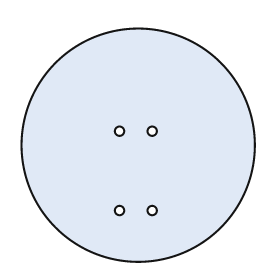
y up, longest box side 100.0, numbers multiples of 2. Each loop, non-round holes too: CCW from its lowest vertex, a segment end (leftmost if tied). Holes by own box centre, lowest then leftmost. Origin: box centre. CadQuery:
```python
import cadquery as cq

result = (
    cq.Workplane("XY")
    .moveTo(0.0, 0.0)
    .circle(50.0)
    .moveTo(-8.0, -28.0)
    .circle(2.0)
    .moveTo(6.0, -28.0)
    .circle(2.0)
    .moveTo(-8.0, 6.0)
    .circle(2.0)
    .moveTo(6.0, 6.0)
    .circle(2.0)
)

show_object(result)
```